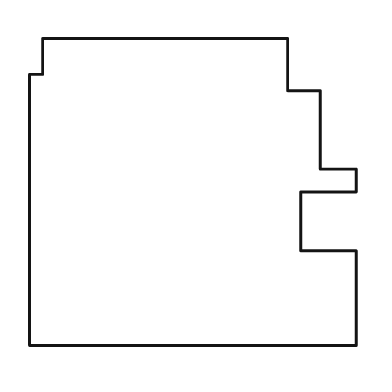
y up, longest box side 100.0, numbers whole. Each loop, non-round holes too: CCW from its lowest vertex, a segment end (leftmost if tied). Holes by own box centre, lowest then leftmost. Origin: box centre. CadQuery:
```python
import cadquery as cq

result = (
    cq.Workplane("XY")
    .moveTo(-50.0, -47.0)
    .lineTo(50.0, -47.0)
    .lineTo(50.0, -18.0)
    .lineTo(33.0, -18.0)
    .lineTo(33.0, 0.0)
    .lineTo(50.0, 0.0)
    .lineTo(50.0, 7.0)
    .lineTo(39.0, 7.0)
    .lineTo(39.0, 31.0)
    .lineTo(29.0, 31.0)
    .lineTo(29.0, 47.0)
    .lineTo(-46.0, 47.0)
    .lineTo(-46.0, 36.0)
    .lineTo(-50.0, 36.0)
    .close()
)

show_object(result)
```